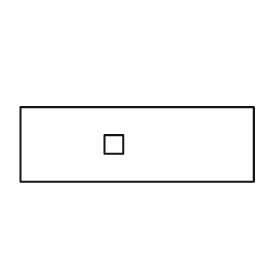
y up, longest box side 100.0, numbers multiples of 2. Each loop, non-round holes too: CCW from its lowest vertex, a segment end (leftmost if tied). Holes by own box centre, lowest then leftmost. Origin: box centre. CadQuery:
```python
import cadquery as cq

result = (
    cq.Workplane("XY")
    .moveTo(-50.0, -16.0)
    .lineTo(50.0, -16.0)
    .lineTo(50.0, 16.0)
    .lineTo(-50.0, 16.0)
    .close()
    .moveTo(-14.0, -4.0)
    .lineTo(-6.0, -4.0)
    .lineTo(-6.0, 4.0)
    .lineTo(-14.0, 4.0)
    .close()
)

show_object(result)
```